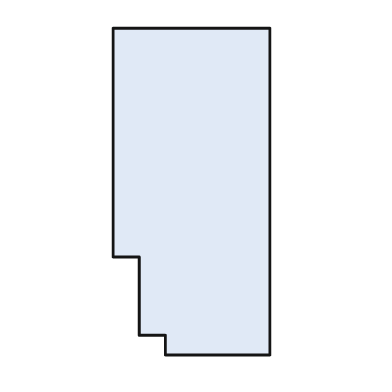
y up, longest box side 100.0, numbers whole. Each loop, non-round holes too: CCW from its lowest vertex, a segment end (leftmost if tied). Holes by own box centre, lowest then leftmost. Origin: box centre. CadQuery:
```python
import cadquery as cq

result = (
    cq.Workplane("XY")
    .moveTo(-8.0, -50.0)
    .lineTo(24.0, -50.0)
    .lineTo(24.0, 50.0)
    .lineTo(-24.0, 50.0)
    .lineTo(-24.0, -20.0)
    .lineTo(-16.0, -20.0)
    .lineTo(-16.0, -44.0)
    .lineTo(-8.0, -44.0)
    .close()
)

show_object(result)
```